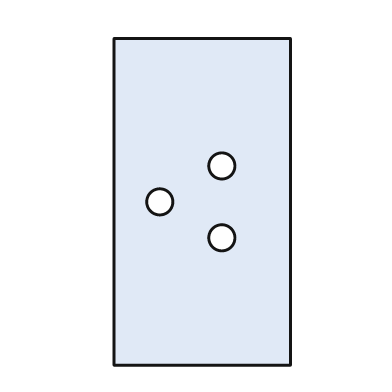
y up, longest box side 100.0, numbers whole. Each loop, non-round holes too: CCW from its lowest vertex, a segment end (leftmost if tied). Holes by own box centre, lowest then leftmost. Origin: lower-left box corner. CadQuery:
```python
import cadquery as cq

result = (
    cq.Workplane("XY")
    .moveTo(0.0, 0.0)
    .lineTo(54.0, 0.0)
    .lineTo(54.0, 100.0)
    .lineTo(0.0, 100.0)
    .close()
    .moveTo(33.0, 39.0)
    .circle(4.0)
    .moveTo(14.0, 50.0)
    .circle(4.0)
    .moveTo(33.0, 61.0)
    .circle(4.0)
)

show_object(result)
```